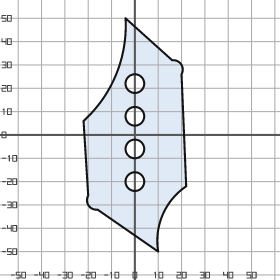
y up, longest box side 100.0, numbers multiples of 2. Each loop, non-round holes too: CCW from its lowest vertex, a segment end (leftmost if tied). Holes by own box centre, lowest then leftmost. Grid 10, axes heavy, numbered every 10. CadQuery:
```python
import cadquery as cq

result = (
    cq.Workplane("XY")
    .moveTo(10.0, -50.0)
    .threePointArc((12.0, -34.0), (22.0, -22.0))
    .lineTo(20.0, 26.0)
    .threePointArc((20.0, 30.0), (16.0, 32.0))
    .lineTo(-4.0, 50.0)
    .threePointArc((-8.0, 26.0), (-22.0, 6.0))
    .lineTo(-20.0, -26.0)
    .threePointArc((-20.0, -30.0), (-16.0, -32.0))
    .close()
    .moveTo(0.0, -20.0)
    .circle(4.0)
    .moveTo(0.0, -6.0)
    .circle(4.0)
    .moveTo(0.0, 8.0)
    .circle(4.0)
    .moveTo(0.0, 22.0)
    .circle(4.0)
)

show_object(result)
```